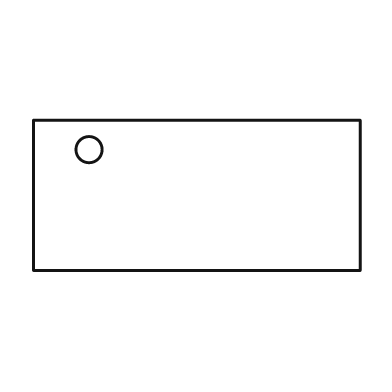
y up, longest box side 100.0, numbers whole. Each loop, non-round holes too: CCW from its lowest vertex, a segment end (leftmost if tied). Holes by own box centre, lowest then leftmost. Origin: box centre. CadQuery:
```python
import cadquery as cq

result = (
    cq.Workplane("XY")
    .moveTo(-50.0, -23.0)
    .lineTo(50.0, -23.0)
    .lineTo(50.0, 23.0)
    .lineTo(-50.0, 23.0)
    .close()
    .moveTo(-33.0, 14.0)
    .circle(4.0)
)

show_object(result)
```